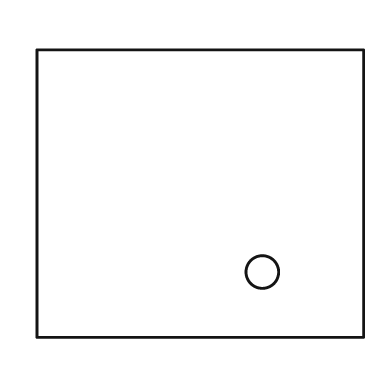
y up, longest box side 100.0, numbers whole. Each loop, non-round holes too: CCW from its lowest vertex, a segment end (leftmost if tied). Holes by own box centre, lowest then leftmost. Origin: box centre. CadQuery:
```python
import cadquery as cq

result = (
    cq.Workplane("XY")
    .moveTo(-50.0, -44.0)
    .lineTo(50.0, -44.0)
    .lineTo(50.0, 44.0)
    .lineTo(-50.0, 44.0)
    .close()
    .moveTo(19.0, -24.0)
    .circle(5.0)
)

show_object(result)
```